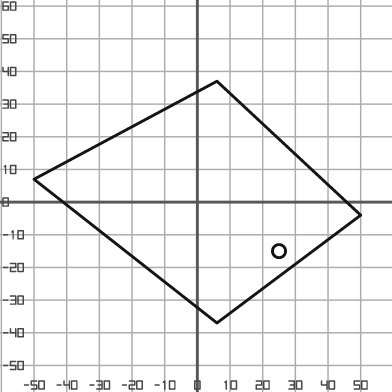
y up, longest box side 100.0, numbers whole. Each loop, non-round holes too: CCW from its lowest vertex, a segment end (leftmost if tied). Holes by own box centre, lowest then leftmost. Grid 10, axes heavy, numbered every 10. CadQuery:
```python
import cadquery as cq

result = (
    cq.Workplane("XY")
    .moveTo(6.0, -37.0)
    .lineTo(50.0, -4.0)
    .lineTo(6.0, 37.0)
    .lineTo(-50.0, 7.0)
    .close()
    .moveTo(25.0, -15.0)
    .circle(2.0)
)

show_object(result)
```